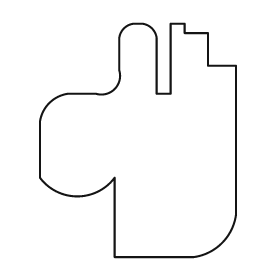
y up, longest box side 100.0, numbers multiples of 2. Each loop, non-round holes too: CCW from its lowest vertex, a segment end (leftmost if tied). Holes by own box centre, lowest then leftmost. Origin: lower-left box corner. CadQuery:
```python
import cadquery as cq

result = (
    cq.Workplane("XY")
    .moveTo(32.0, 0.0)
    .lineTo(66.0, 0.0)
    .threePointArc((78.0, 6.0), (84.0, 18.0))
    .lineTo(84.0, 82.0)
    .lineTo(72.0, 82.0)
    .lineTo(72.0, 96.0)
    .lineTo(62.0, 96.0)
    .lineTo(62.0, 100.0)
    .lineTo(56.0, 100.0)
    .lineTo(56.0, 70.0)
    .lineTo(50.0, 70.0)
    .lineTo(50.0, 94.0)
    .threePointArc((48.0, 98.0), (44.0, 100.0))
    .lineTo(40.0, 100.0)
    .threePointArc((36.0, 98.0), (34.0, 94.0))
    .lineTo(34.0, 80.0)
    .threePointArc((32.0, 72.0), (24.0, 70.0))
    .lineTo(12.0, 70.0)
    .threePointArc((4.0, 66.0), (0.0, 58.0))
    .lineTo(0.0, 34.0)
    .threePointArc((16.0, 26.0), (32.0, 34.0))
    .close()
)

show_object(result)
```